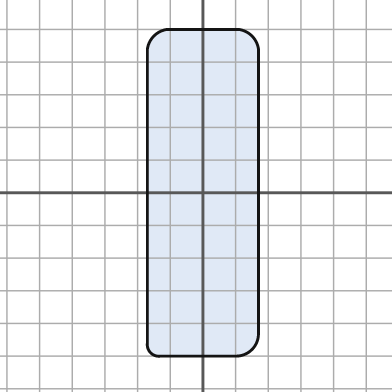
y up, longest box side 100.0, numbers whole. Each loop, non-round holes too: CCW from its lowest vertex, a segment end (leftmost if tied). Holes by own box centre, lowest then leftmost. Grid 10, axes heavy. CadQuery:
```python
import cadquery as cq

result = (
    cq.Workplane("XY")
    .moveTo(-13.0, -50.0)
    .lineTo(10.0, -50.0)
    .threePointArc((15.0, -48.0), (17.0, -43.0))
    .lineTo(17.0, 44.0)
    .threePointArc((15.0, 48.0), (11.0, 50.0))
    .lineTo(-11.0, 50.0)
    .threePointArc((-15.0, 48.0), (-17.0, 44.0))
    .lineTo(-17.0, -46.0)
    .threePointArc((-16.0, -49.0), (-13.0, -50.0))
    .close()
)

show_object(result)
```